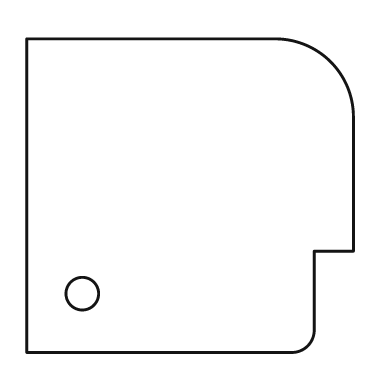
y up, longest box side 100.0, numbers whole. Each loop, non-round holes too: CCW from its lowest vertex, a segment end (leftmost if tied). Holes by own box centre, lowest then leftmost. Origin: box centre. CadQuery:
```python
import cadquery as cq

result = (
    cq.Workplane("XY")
    .moveTo(-50.0, -48.0)
    .lineTo(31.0, -48.0)
    .threePointArc((36.0, -46.0), (38.0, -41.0))
    .lineTo(38.0, -17.0)
    .lineTo(50.0, -17.0)
    .lineTo(50.0, 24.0)
    .threePointArc((43.0, 41.0), (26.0, 48.0))
    .lineTo(-50.0, 48.0)
    .close()
    .moveTo(-33.0, -30.0)
    .circle(5.0)
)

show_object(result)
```